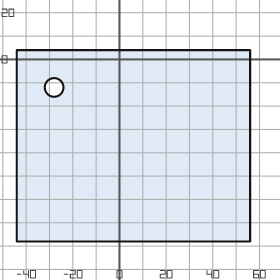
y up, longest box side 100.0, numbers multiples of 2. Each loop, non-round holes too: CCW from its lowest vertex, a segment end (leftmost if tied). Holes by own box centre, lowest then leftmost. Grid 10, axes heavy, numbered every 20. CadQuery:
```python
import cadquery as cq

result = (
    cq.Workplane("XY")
    .moveTo(-44.0, -78.0)
    .lineTo(56.0, -78.0)
    .lineTo(56.0, 4.0)
    .lineTo(-44.0, 4.0)
    .close()
    .moveTo(-28.0, -12.0)
    .circle(4.0)
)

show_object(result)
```